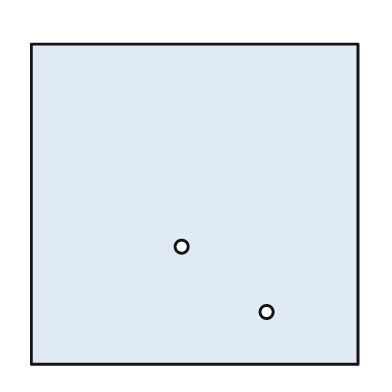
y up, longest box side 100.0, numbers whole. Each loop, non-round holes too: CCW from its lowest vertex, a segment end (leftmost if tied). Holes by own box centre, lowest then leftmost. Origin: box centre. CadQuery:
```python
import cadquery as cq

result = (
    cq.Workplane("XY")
    .moveTo(-50.0, -49.0)
    .lineTo(50.0, -49.0)
    .lineTo(50.0, 49.0)
    .lineTo(-50.0, 49.0)
    .close()
    .moveTo(22.0, -33.0)
    .circle(2.0)
    .moveTo(-4.0, -13.0)
    .circle(2.0)
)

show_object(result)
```